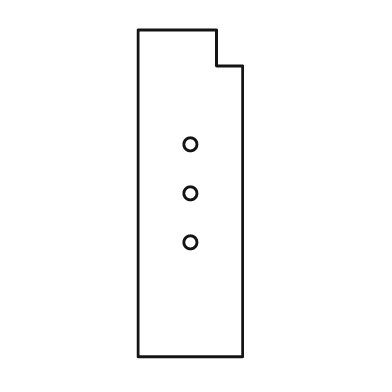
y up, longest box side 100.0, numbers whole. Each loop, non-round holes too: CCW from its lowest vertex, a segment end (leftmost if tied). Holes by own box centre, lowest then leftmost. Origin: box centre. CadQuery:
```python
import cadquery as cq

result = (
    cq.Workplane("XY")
    .moveTo(-16.0, -50.0)
    .lineTo(16.0, -50.0)
    .lineTo(16.0, 39.0)
    .lineTo(8.0, 39.0)
    .lineTo(8.0, 50.0)
    .lineTo(-16.0, 50.0)
    .close()
    .moveTo(0.0, -15.0)
    .circle(2.0)
    .moveTo(0.0, 0.0)
    .circle(2.0)
    .moveTo(0.0, 15.0)
    .circle(2.0)
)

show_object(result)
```